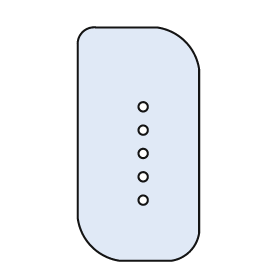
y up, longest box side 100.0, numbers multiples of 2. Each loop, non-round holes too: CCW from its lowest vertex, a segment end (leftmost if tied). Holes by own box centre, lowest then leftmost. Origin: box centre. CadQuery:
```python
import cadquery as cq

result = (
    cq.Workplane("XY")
    .moveTo(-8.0, -50.0)
    .lineTo(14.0, -50.0)
    .threePointArc((22.0, -46.0), (26.0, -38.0))
    .lineTo(26.0, 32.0)
    .threePointArc((20.0, 44.0), (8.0, 50.0))
    .lineTo(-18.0, 50.0)
    .threePointArc((-24.0, 48.0), (-26.0, 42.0))
    .lineTo(-26.0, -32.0)
    .threePointArc((-20.0, -44.0), (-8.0, -50.0))
    .close()
    .moveTo(2.0, -24.0)
    .circle(2.0)
    .moveTo(2.0, -14.0)
    .circle(2.0)
    .moveTo(2.0, -4.0)
    .circle(2.0)
    .moveTo(2.0, 6.0)
    .circle(2.0)
    .moveTo(2.0, 16.0)
    .circle(2.0)
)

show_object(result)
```